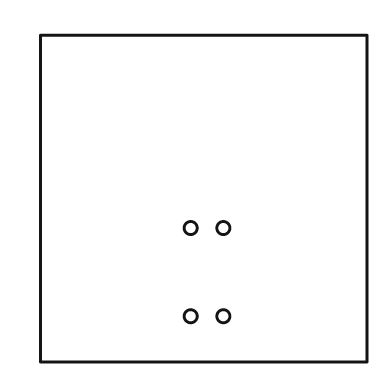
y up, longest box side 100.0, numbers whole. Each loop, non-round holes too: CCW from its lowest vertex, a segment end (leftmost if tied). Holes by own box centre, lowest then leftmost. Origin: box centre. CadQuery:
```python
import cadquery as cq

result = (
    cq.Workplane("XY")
    .moveTo(-50.0, -50.0)
    .lineTo(50.0, -50.0)
    .lineTo(50.0, 50.0)
    .lineTo(-50.0, 50.0)
    .close()
    .moveTo(-4.0, -36.0)
    .circle(2.0)
    .moveTo(6.0, -36.0)
    .circle(2.0)
    .moveTo(-4.0, -9.0)
    .circle(2.0)
    .moveTo(6.0, -9.0)
    .circle(2.0)
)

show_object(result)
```